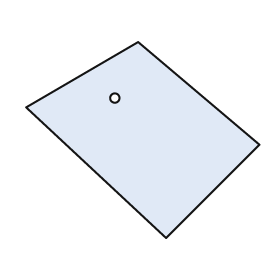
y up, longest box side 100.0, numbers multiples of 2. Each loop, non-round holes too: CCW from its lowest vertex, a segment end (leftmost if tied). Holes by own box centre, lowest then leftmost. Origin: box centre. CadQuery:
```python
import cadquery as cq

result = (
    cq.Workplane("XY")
    .moveTo(10.0, -42.0)
    .lineTo(50.0, -2.0)
    .lineTo(-2.0, 42.0)
    .lineTo(-50.0, 14.0)
    .close()
    .moveTo(-12.0, 18.0)
    .circle(2.0)
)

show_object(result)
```